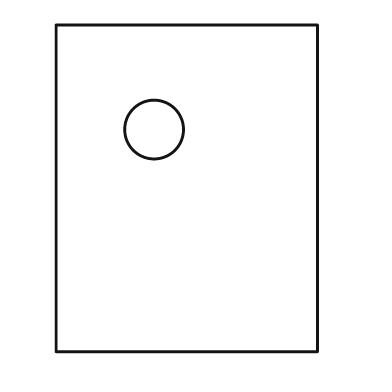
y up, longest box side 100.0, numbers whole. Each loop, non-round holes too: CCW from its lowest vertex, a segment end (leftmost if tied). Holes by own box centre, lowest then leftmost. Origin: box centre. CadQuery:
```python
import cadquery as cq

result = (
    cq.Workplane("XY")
    .moveTo(-40.0, -50.0)
    .lineTo(40.0, -50.0)
    .lineTo(40.0, 50.0)
    .lineTo(-40.0, 50.0)
    .close()
    .moveTo(-10.0, 18.0)
    .circle(9.0)
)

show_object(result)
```